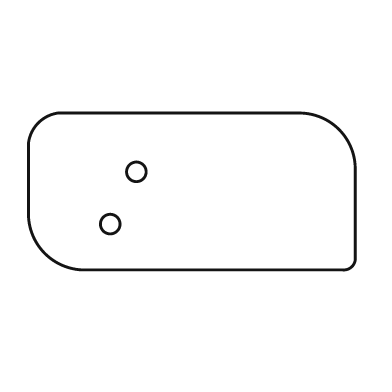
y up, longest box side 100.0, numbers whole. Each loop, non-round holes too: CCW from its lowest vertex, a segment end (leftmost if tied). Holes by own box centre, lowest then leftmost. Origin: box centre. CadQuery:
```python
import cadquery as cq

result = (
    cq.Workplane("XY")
    .moveTo(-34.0, -24.0)
    .lineTo(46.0, -24.0)
    .threePointArc((49.0, -23.0), (50.0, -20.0))
    .lineTo(50.0, 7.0)
    .threePointArc((45.0, 19.0), (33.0, 24.0))
    .lineTo(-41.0, 24.0)
    .threePointArc((-47.0, 21.0), (-50.0, 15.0))
    .lineTo(-50.0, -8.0)
    .threePointArc((-45.0, -19.0), (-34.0, -24.0))
    .close()
    .moveTo(-25.0, -10.0)
    .circle(3.0)
    .moveTo(-17.0, 6.0)
    .circle(3.0)
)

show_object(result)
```